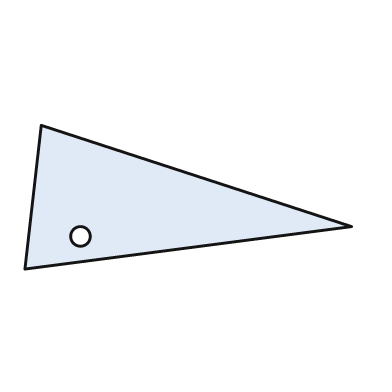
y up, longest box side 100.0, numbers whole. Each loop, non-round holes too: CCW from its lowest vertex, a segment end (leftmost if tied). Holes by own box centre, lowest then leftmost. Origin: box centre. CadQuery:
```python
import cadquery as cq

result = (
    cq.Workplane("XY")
    .moveTo(-50.0, -22.0)
    .lineTo(50.0, -9.0)
    .lineTo(-45.0, 22.0)
    .close()
    .moveTo(-33.0, -12.0)
    .circle(3.0)
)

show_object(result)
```